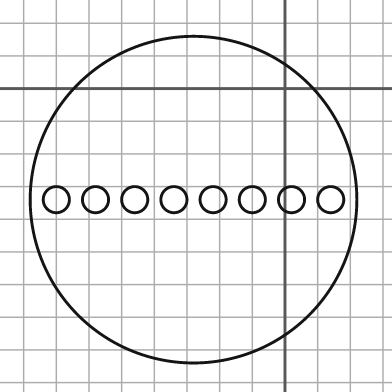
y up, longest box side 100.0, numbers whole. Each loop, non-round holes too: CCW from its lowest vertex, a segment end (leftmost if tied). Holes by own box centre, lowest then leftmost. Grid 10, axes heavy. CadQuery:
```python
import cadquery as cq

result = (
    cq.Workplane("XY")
    .moveTo(-28.0, -34.0)
    .circle(50.0)
    .moveTo(-70.0, -34.0)
    .circle(4.0)
    .moveTo(-58.0, -34.0)
    .circle(4.0)
    .moveTo(-46.0, -34.0)
    .circle(4.0)
    .moveTo(-34.0, -34.0)
    .circle(4.0)
    .moveTo(-22.0, -34.0)
    .circle(4.0)
    .moveTo(-10.0, -34.0)
    .circle(4.0)
    .moveTo(2.0, -34.0)
    .circle(4.0)
    .moveTo(14.0, -34.0)
    .circle(4.0)
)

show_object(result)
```